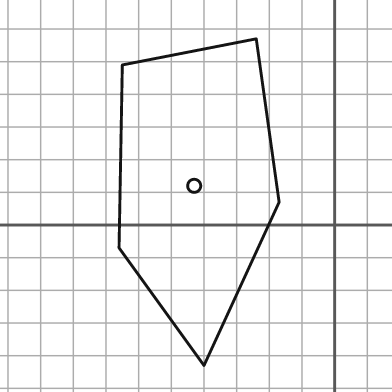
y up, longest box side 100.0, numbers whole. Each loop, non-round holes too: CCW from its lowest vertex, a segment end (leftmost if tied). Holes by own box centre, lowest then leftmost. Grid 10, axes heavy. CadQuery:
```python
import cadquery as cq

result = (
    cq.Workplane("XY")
    .moveTo(-40.0, -43.0)
    .lineTo(-17.0, 7.0)
    .lineTo(-24.0, 57.0)
    .lineTo(-65.0, 49.0)
    .lineTo(-66.0, -7.0)
    .close()
    .moveTo(-43.0, 12.0)
    .circle(2.0)
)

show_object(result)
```